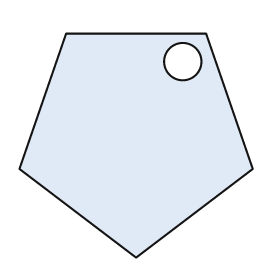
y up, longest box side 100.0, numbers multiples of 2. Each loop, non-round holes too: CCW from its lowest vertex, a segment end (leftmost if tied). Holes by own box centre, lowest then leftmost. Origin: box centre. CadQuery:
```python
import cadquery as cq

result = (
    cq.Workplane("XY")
    .moveTo(0.0, -48.0)
    .lineTo(50.0, -10.0)
    .lineTo(30.0, 48.0)
    .lineTo(-30.0, 48.0)
    .lineTo(-50.0, -10.0)
    .close()
    .moveTo(20.0, 36.0)
    .circle(8.0)
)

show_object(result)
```